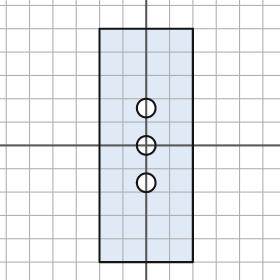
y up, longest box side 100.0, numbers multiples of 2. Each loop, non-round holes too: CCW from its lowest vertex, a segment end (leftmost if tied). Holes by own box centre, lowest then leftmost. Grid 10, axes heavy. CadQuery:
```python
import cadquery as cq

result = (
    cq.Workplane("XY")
    .moveTo(-20.0, -50.0)
    .lineTo(20.0, -50.0)
    .lineTo(20.0, 50.0)
    .lineTo(-20.0, 50.0)
    .close()
    .moveTo(0.0, -16.0)
    .circle(4.0)
    .moveTo(0.0, 0.0)
    .circle(4.0)
    .moveTo(0.0, 16.0)
    .circle(4.0)
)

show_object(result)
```